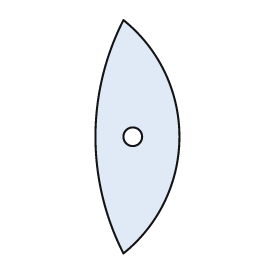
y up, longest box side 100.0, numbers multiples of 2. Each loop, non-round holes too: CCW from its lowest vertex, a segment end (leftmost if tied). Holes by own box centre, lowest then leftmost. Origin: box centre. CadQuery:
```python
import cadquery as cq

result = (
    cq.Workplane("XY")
    .moveTo(-6.0, -50.0)
    .threePointArc((18.0, 0.0), (-6.0, 50.0))
    .threePointArc((-18.0, 0.0), (-6.0, -50.0))
    .close()
    .moveTo(-2.0, 0.0)
    .circle(4.0)
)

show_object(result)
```